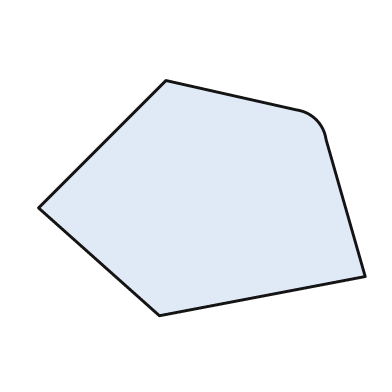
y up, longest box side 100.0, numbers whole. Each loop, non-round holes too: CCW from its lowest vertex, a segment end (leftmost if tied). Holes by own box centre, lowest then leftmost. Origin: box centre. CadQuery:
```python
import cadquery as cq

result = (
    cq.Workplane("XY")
    .moveTo(-13.0, -36.0)
    .lineTo(50.0, -24.0)
    .lineTo(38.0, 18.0)
    .threePointArc((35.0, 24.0), (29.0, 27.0))
    .lineTo(-11.0, 36.0)
    .lineTo(-50.0, -3.0)
    .close()
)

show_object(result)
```